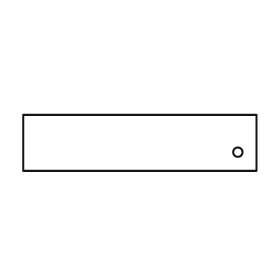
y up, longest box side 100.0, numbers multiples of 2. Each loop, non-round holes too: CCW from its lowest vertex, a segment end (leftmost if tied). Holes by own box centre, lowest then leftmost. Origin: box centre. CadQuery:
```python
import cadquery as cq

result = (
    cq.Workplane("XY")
    .moveTo(-50.0, -12.0)
    .lineTo(50.0, -12.0)
    .lineTo(50.0, 12.0)
    .lineTo(-50.0, 12.0)
    .close()
    .moveTo(42.0, -4.0)
    .circle(2.0)
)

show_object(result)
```